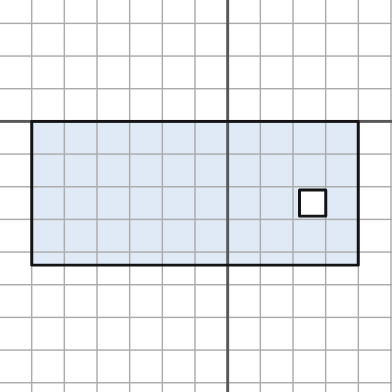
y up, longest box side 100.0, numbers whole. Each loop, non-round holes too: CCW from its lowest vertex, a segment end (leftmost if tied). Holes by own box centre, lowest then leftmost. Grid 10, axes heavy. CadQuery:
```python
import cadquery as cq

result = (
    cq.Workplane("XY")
    .moveTo(-60.0, -44.0)
    .lineTo(40.0, -44.0)
    .lineTo(40.0, 0.0)
    .lineTo(-60.0, 0.0)
    .close()
    .moveTo(22.0, -29.0)
    .lineTo(30.0, -29.0)
    .lineTo(30.0, -21.0)
    .lineTo(22.0, -21.0)
    .close()
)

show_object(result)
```